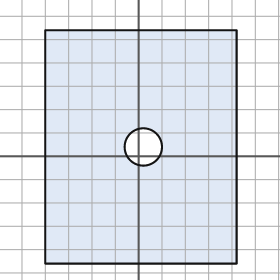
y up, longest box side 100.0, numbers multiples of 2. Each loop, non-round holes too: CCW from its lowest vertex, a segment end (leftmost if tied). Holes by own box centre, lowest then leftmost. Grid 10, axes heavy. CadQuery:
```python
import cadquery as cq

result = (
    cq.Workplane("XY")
    .moveTo(-40.0, -46.0)
    .lineTo(42.0, -46.0)
    .lineTo(42.0, 54.0)
    .lineTo(-40.0, 54.0)
    .close()
    .moveTo(2.0, 4.0)
    .circle(8.0)
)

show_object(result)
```